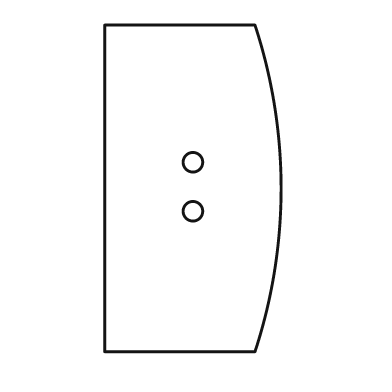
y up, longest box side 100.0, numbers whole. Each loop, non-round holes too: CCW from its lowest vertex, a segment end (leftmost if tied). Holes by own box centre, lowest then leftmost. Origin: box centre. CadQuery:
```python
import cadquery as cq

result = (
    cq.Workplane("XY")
    .moveTo(-27.0, -50.0)
    .lineTo(19.0, -50.0)
    .threePointArc((27.0, 0.0), (19.0, 50.0))
    .lineTo(-27.0, 50.0)
    .close()
    .moveTo(0.0, -7.0)
    .circle(3.0)
    .moveTo(0.0, 8.0)
    .circle(3.0)
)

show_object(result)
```